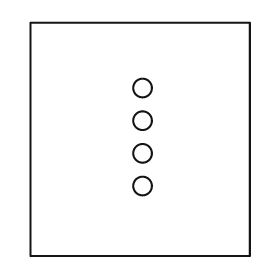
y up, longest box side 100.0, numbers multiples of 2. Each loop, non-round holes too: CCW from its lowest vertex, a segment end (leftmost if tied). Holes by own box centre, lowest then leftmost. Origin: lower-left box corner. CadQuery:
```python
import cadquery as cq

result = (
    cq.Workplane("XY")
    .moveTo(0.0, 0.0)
    .lineTo(94.0, 0.0)
    .lineTo(94.0, 100.0)
    .lineTo(0.0, 100.0)
    .close()
    .moveTo(48.0, 30.0)
    .circle(4.0)
    .moveTo(48.0, 44.0)
    .circle(4.0)
    .moveTo(48.0, 58.0)
    .circle(4.0)
    .moveTo(48.0, 72.0)
    .circle(4.0)
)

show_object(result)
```